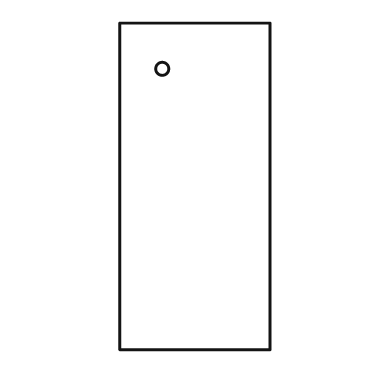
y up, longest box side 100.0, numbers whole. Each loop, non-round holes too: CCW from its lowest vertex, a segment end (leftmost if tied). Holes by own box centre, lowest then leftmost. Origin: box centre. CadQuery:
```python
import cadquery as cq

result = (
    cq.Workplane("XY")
    .moveTo(-23.0, -50.0)
    .lineTo(23.0, -50.0)
    .lineTo(23.0, 50.0)
    .lineTo(-23.0, 50.0)
    .close()
    .moveTo(-10.0, 36.0)
    .circle(2.0)
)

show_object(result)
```